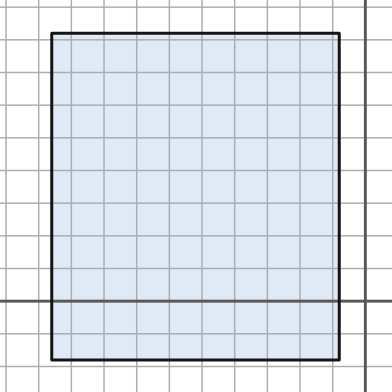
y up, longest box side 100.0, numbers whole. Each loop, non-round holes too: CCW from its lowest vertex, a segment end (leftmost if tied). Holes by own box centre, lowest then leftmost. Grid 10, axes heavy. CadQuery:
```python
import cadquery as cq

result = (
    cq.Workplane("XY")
    .moveTo(-96.0, -18.0)
    .lineTo(-8.0, -18.0)
    .lineTo(-8.0, 82.0)
    .lineTo(-96.0, 82.0)
    .close()
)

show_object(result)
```